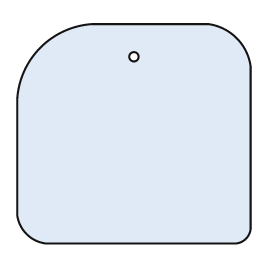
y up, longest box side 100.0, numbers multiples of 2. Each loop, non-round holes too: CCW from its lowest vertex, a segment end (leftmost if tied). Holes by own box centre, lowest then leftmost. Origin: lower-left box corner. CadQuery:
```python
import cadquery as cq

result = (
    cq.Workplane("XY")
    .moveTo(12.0, 0.0)
    .lineTo(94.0, 0.0)
    .threePointArc((98.0, 2.0), (100.0, 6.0))
    .lineTo(100.0, 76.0)
    .threePointArc((94.0, 88.0), (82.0, 94.0))
    .lineTo(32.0, 94.0)
    .threePointArc((10.0, 84.0), (0.0, 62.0))
    .lineTo(0.0, 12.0)
    .threePointArc((4.0, 4.0), (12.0, 0.0))
    .close()
    .moveTo(50.0, 80.0)
    .circle(2.0)
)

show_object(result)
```